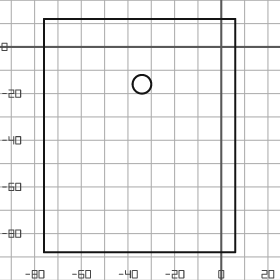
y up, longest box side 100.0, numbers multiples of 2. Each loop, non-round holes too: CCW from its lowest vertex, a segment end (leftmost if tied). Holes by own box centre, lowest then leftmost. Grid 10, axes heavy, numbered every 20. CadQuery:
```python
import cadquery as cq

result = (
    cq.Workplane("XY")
    .moveTo(-76.0, -88.0)
    .lineTo(6.0, -88.0)
    .lineTo(6.0, 12.0)
    .lineTo(-76.0, 12.0)
    .close()
    .moveTo(-34.0, -16.0)
    .circle(4.0)
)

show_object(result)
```